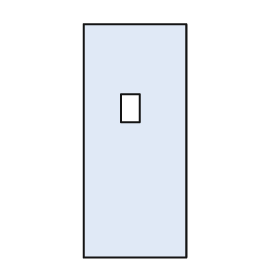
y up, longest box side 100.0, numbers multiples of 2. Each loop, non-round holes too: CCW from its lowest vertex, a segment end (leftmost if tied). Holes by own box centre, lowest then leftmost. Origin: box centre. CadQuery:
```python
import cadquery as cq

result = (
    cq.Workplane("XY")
    .moveTo(-22.0, -50.0)
    .lineTo(22.0, -50.0)
    .lineTo(22.0, 50.0)
    .lineTo(-22.0, 50.0)
    .close()
    .moveTo(-6.0, 8.0)
    .lineTo(2.0, 8.0)
    .lineTo(2.0, 20.0)
    .lineTo(-6.0, 20.0)
    .close()
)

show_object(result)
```